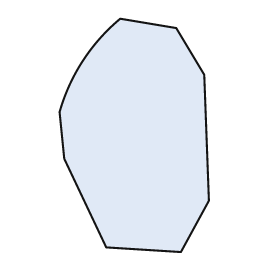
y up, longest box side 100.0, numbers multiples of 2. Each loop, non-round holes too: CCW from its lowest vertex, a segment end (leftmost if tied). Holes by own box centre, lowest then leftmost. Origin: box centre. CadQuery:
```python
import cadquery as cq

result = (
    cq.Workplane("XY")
    .moveTo(20.0, -50.0)
    .lineTo(32.0, -28.0)
    .lineTo(30.0, 26.0)
    .lineTo(18.0, 46.0)
    .lineTo(-6.0, 50.0)
    .threePointArc((-22.0, 32.0), (-32.0, 10.0))
    .lineTo(-30.0, -10.0)
    .lineTo(-12.0, -48.0)
    .close()
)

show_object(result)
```